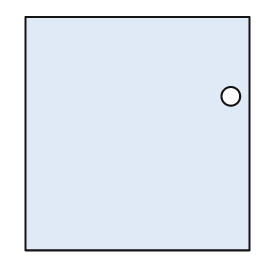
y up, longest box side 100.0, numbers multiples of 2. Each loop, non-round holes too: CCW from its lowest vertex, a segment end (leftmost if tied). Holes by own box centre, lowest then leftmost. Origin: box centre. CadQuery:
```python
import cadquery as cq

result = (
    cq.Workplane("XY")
    .moveTo(-48.0, -50.0)
    .lineTo(48.0, -50.0)
    .lineTo(48.0, 50.0)
    .lineTo(-48.0, 50.0)
    .close()
    .moveTo(40.0, 16.0)
    .circle(4.0)
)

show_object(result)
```